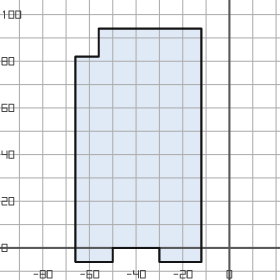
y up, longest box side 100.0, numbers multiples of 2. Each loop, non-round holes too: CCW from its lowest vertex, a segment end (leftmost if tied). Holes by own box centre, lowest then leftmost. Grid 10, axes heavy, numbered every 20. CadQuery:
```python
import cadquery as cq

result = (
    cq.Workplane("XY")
    .moveTo(-66.0, -6.0)
    .lineTo(-50.0, -6.0)
    .lineTo(-50.0, 0.0)
    .lineTo(-30.0, 0.0)
    .lineTo(-30.0, -6.0)
    .lineTo(-12.0, -6.0)
    .lineTo(-12.0, 94.0)
    .lineTo(-56.0, 94.0)
    .lineTo(-56.0, 82.0)
    .lineTo(-66.0, 82.0)
    .close()
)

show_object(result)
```